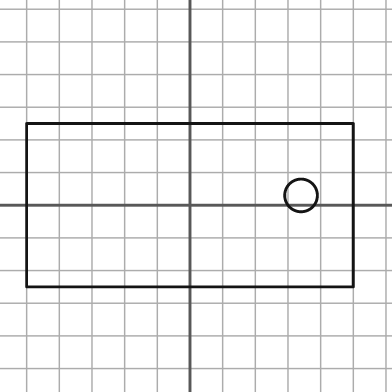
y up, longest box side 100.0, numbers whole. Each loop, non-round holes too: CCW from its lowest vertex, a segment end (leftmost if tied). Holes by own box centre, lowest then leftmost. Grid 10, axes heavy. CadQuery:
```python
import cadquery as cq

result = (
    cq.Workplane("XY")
    .moveTo(-50.0, -25.0)
    .lineTo(50.0, -25.0)
    .lineTo(50.0, 25.0)
    .lineTo(-50.0, 25.0)
    .close()
    .moveTo(34.0, 3.0)
    .circle(5.0)
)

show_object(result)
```